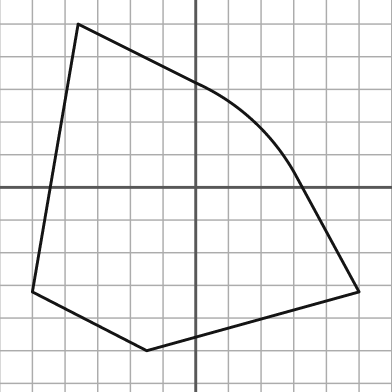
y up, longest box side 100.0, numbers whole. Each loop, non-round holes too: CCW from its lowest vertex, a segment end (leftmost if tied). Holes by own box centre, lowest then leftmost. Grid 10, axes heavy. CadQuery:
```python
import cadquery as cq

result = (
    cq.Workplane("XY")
    .moveTo(-15.0, -50.0)
    .lineTo(50.0, -32.0)
    .lineTo(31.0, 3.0)
    .threePointArc((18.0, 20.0), (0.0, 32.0))
    .lineTo(-36.0, 50.0)
    .lineTo(-50.0, -32.0)
    .close()
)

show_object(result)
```